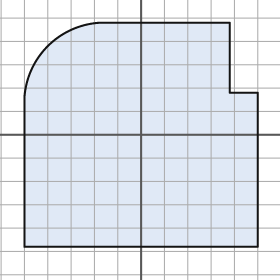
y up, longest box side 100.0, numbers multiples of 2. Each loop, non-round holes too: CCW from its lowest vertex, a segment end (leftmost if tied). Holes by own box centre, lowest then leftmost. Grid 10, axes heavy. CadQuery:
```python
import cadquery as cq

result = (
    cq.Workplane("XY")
    .moveTo(-50.0, -48.0)
    .lineTo(50.0, -48.0)
    .lineTo(50.0, 18.0)
    .lineTo(38.0, 18.0)
    .lineTo(38.0, 48.0)
    .lineTo(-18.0, 48.0)
    .threePointArc((-40.0, 38.0), (-50.0, 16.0))
    .close()
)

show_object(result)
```